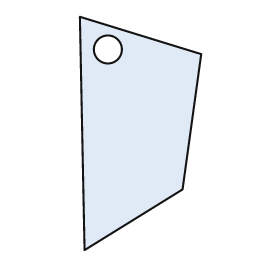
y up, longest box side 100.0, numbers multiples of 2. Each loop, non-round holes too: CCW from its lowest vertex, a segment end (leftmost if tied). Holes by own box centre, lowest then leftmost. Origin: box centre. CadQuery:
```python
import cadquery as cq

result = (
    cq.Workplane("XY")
    .moveTo(-24.0, -50.0)
    .lineTo(18.0, -24.0)
    .lineTo(26.0, 34.0)
    .lineTo(-26.0, 50.0)
    .close()
    .moveTo(-14.0, 36.0)
    .circle(6.0)
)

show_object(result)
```